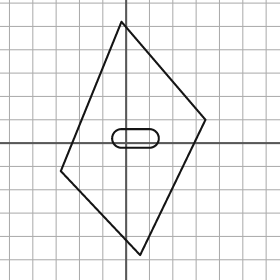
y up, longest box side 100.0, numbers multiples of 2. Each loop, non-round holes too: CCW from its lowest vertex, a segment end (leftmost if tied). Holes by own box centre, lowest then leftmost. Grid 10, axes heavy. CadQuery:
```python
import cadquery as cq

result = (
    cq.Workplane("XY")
    .moveTo(6.0, -48.0)
    .lineTo(34.0, 10.0)
    .lineTo(-2.0, 52.0)
    .lineTo(-28.0, -12.0)
    .close()
    .moveTo(-2.0, -2.0)
    .lineTo(10.0, -2.0)
    .threePointArc((14.0, 2.0), (10.0, 6.0))
    .lineTo(-2.0, 6.0)
    .threePointArc((-6.0, 2.0), (-2.0, -2.0))
    .close()
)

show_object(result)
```